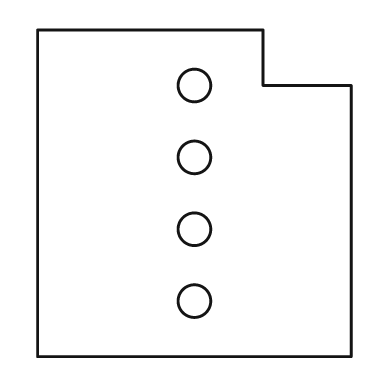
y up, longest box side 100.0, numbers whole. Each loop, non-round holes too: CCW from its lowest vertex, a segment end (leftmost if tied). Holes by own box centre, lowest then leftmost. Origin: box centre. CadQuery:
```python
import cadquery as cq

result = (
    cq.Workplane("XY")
    .moveTo(-48.0, -50.0)
    .lineTo(48.0, -50.0)
    .lineTo(48.0, 33.0)
    .lineTo(21.0, 33.0)
    .lineTo(21.0, 50.0)
    .lineTo(-48.0, 50.0)
    .close()
    .moveTo(0.0, -33.0)
    .circle(5.0)
    .moveTo(0.0, -11.0)
    .circle(5.0)
    .moveTo(0.0, 11.0)
    .circle(5.0)
    .moveTo(0.0, 33.0)
    .circle(5.0)
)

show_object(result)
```